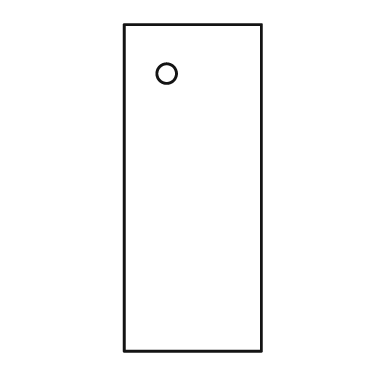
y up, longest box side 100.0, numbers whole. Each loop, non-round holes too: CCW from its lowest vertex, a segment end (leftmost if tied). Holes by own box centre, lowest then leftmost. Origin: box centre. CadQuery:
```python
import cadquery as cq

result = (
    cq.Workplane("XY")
    .moveTo(-21.0, -50.0)
    .lineTo(21.0, -50.0)
    .lineTo(21.0, 50.0)
    .lineTo(-21.0, 50.0)
    .close()
    .moveTo(-8.0, 35.0)
    .circle(3.0)
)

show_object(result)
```